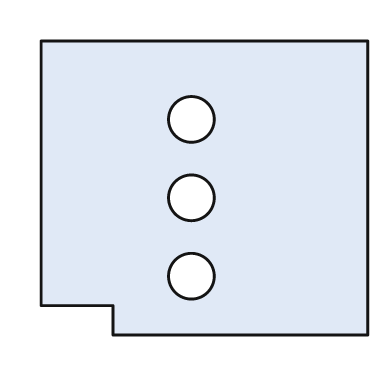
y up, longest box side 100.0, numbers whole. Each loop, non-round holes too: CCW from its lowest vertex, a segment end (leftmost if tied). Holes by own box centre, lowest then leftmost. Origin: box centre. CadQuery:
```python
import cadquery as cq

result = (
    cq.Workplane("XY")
    .moveTo(-28.0, -45.0)
    .lineTo(50.0, -45.0)
    .lineTo(50.0, 45.0)
    .lineTo(-50.0, 45.0)
    .lineTo(-50.0, -36.0)
    .lineTo(-28.0, -36.0)
    .close()
    .moveTo(-4.0, -27.0)
    .circle(7.0)
    .moveTo(-4.0, -3.0)
    .circle(7.0)
    .moveTo(-4.0, 21.0)
    .circle(7.0)
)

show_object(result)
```